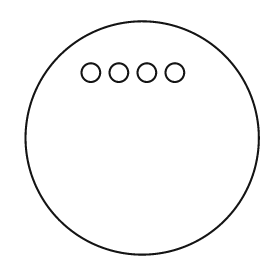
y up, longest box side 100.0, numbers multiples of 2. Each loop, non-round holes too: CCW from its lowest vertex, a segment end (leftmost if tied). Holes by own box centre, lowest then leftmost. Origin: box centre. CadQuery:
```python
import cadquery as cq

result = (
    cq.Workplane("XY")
    .moveTo(0.0, 0.0)
    .circle(50.0)
    .moveTo(-22.0, 28.0)
    .circle(4.0)
    .moveTo(-10.0, 28.0)
    .circle(4.0)
    .moveTo(2.0, 28.0)
    .circle(4.0)
    .moveTo(14.0, 28.0)
    .circle(4.0)
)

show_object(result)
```